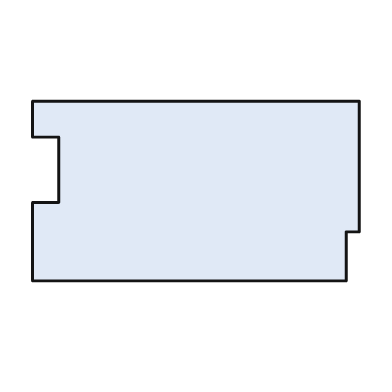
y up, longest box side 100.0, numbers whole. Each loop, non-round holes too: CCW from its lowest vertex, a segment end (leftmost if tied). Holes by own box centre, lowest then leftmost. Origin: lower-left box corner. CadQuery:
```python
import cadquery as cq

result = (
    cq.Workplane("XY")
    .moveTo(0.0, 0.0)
    .lineTo(96.0, 0.0)
    .lineTo(96.0, 15.0)
    .lineTo(100.0, 15.0)
    .lineTo(100.0, 55.0)
    .lineTo(0.0, 55.0)
    .lineTo(0.0, 44.0)
    .lineTo(8.0, 44.0)
    .lineTo(8.0, 24.0)
    .lineTo(0.0, 24.0)
    .close()
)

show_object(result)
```